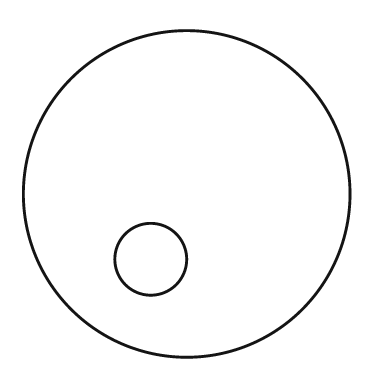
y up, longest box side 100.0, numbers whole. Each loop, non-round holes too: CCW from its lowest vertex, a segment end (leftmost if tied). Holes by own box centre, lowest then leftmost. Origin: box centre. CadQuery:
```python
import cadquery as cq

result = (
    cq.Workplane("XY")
    .moveTo(0.0, 0.0)
    .circle(50.0)
    .moveTo(-11.0, -20.0)
    .circle(11.0)
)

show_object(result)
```